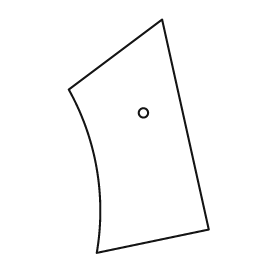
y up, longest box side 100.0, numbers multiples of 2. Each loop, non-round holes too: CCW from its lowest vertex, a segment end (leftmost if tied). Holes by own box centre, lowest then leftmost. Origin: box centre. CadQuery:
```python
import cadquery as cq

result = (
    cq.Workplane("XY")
    .moveTo(-18.0, -50.0)
    .lineTo(30.0, -40.0)
    .lineTo(10.0, 50.0)
    .lineTo(-30.0, 20.0)
    .threePointArc((-18.0, -14.0), (-18.0, -50.0))
    .close()
    .moveTo(2.0, 10.0)
    .circle(2.0)
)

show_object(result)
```